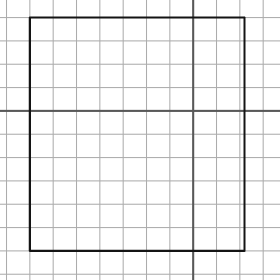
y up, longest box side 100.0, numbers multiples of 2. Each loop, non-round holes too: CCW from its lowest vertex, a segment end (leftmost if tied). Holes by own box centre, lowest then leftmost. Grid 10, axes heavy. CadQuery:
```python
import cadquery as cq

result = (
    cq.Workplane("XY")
    .moveTo(-70.0, -60.0)
    .lineTo(22.0, -60.0)
    .lineTo(22.0, 40.0)
    .lineTo(-70.0, 40.0)
    .close()
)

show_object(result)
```